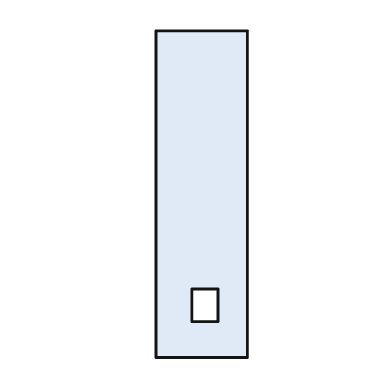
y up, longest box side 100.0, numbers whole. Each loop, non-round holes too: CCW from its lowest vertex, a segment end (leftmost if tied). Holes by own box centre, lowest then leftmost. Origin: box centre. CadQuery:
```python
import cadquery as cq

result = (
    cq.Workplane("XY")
    .moveTo(-14.0, -50.0)
    .lineTo(14.0, -50.0)
    .lineTo(14.0, 50.0)
    .lineTo(-14.0, 50.0)
    .close()
    .moveTo(-3.0, -39.0)
    .lineTo(5.0, -39.0)
    .lineTo(5.0, -29.0)
    .lineTo(-3.0, -29.0)
    .close()
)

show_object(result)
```